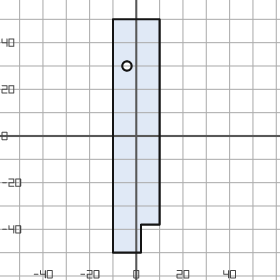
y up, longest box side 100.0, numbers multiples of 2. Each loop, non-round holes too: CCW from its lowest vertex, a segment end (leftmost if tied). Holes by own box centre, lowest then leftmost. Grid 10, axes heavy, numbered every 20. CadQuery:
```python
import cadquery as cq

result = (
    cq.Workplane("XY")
    .moveTo(-10.0, -50.0)
    .lineTo(2.0, -50.0)
    .lineTo(2.0, -38.0)
    .lineTo(10.0, -38.0)
    .lineTo(10.0, 50.0)
    .lineTo(-10.0, 50.0)
    .close()
    .moveTo(-4.0, 30.0)
    .circle(2.0)
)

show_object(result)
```